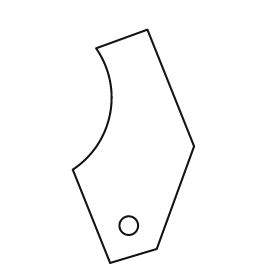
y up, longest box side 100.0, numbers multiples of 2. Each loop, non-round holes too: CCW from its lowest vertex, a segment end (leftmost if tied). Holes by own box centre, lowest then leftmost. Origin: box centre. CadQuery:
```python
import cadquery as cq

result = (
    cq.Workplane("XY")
    .moveTo(-10.0, -50.0)
    .lineTo(10.0, -44.0)
    .lineTo(26.0, 0.0)
    .lineTo(6.0, 50.0)
    .lineTo(-16.0, 42.0)
    .threePointArc((-10.0, 14.0), (-26.0, -10.0))
    .close()
    .moveTo(-2.0, -34.0)
    .circle(4.0)
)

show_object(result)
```